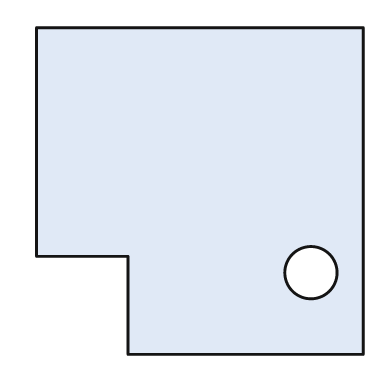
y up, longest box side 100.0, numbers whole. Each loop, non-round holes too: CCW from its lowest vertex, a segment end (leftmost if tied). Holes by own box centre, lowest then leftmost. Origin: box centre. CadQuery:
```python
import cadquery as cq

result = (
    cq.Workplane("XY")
    .moveTo(-22.0, -50.0)
    .lineTo(50.0, -50.0)
    .lineTo(50.0, 50.0)
    .lineTo(-50.0, 50.0)
    .lineTo(-50.0, -20.0)
    .lineTo(-22.0, -20.0)
    .close()
    .moveTo(34.0, -25.0)
    .circle(8.0)
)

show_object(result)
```